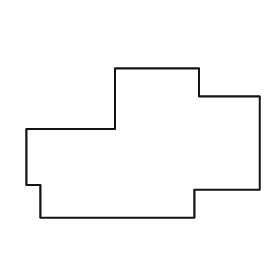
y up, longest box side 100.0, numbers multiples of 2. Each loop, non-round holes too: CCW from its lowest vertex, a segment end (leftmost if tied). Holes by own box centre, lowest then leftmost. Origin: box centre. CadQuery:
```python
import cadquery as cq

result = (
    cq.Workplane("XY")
    .moveTo(-44.0, -32.0)
    .lineTo(22.0, -32.0)
    .lineTo(22.0, -20.0)
    .lineTo(50.0, -20.0)
    .lineTo(50.0, 20.0)
    .lineTo(24.0, 20.0)
    .lineTo(24.0, 32.0)
    .lineTo(-12.0, 32.0)
    .lineTo(-12.0, 6.0)
    .lineTo(-50.0, 6.0)
    .lineTo(-50.0, -18.0)
    .lineTo(-44.0, -18.0)
    .close()
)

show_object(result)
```